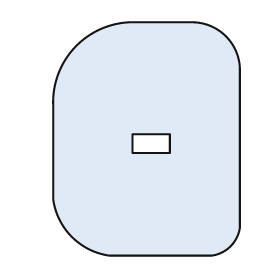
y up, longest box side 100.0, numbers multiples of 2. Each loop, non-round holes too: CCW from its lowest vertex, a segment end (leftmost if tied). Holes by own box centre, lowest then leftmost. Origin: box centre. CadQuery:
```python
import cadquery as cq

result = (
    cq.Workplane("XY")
    .moveTo(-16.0, -50.0)
    .lineTo(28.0, -50.0)
    .threePointArc((36.0, -46.0), (40.0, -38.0))
    .lineTo(40.0, 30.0)
    .threePointArc((34.0, 44.0), (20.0, 50.0))
    .lineTo(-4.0, 50.0)
    .threePointArc((-30.0, 40.0), (-40.0, 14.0))
    .lineTo(-40.0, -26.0)
    .threePointArc((-32.0, -42.0), (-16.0, -50.0))
    .close()
    .moveTo(-6.0, -6.0)
    .lineTo(10.0, -6.0)
    .lineTo(10.0, 2.0)
    .lineTo(-6.0, 2.0)
    .close()
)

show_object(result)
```